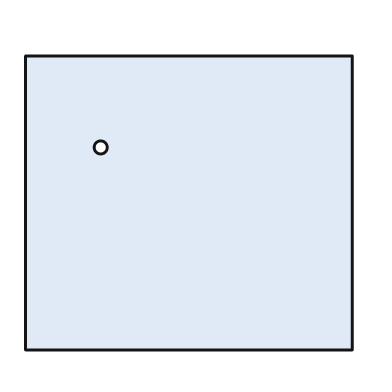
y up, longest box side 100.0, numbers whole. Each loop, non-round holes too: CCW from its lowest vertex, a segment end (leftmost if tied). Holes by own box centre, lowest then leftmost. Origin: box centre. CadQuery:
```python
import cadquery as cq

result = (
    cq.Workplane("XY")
    .moveTo(-50.0, -45.0)
    .lineTo(50.0, -45.0)
    .lineTo(50.0, 45.0)
    .lineTo(-50.0, 45.0)
    .close()
    .moveTo(-27.0, 17.0)
    .circle(2.0)
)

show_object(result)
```